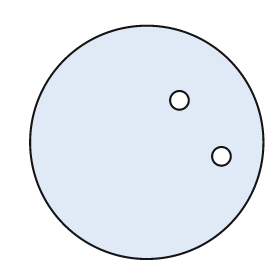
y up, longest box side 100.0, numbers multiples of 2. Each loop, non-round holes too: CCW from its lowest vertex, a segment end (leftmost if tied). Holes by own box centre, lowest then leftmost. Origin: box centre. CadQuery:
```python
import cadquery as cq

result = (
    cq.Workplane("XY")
    .moveTo(0.0, 0.0)
    .circle(50.0)
    .moveTo(32.0, -6.0)
    .circle(4.0)
    .moveTo(14.0, 18.0)
    .circle(4.0)
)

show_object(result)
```